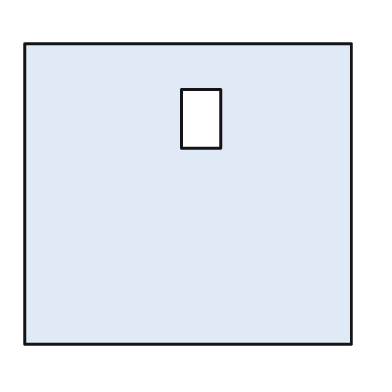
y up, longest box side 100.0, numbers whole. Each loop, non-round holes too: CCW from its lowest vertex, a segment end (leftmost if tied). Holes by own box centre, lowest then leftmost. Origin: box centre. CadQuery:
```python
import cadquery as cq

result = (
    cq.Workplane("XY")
    .moveTo(-50.0, -46.0)
    .lineTo(50.0, -46.0)
    .lineTo(50.0, 46.0)
    .lineTo(-50.0, 46.0)
    .close()
    .moveTo(-2.0, 14.0)
    .lineTo(10.0, 14.0)
    .lineTo(10.0, 32.0)
    .lineTo(-2.0, 32.0)
    .close()
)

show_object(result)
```